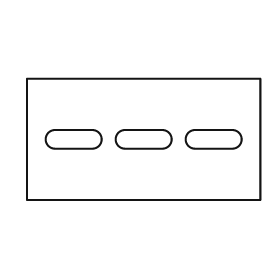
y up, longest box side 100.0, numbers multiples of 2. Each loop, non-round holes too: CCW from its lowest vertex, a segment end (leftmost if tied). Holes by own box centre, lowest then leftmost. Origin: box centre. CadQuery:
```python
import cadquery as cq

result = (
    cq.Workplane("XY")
    .moveTo(-50.0, -26.0)
    .lineTo(50.0, -26.0)
    .lineTo(50.0, 26.0)
    .lineTo(-50.0, 26.0)
    .close()
    .moveTo(-38.0, -4.0)
    .lineTo(-22.0, -4.0)
    .threePointArc((-18.0, 0.0), (-22.0, 4.0))
    .lineTo(-38.0, 4.0)
    .threePointArc((-42.0, 0.0), (-38.0, -4.0))
    .close()
    .moveTo(-8.0, -4.0)
    .lineTo(8.0, -4.0)
    .threePointArc((12.0, 0.0), (8.0, 4.0))
    .lineTo(-8.0, 4.0)
    .threePointArc((-12.0, 0.0), (-8.0, -4.0))
    .close()
    .moveTo(22.0, -4.0)
    .lineTo(38.0, -4.0)
    .threePointArc((42.0, 0.0), (38.0, 4.0))
    .lineTo(22.0, 4.0)
    .threePointArc((18.0, 0.0), (22.0, -4.0))
    .close()
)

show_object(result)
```